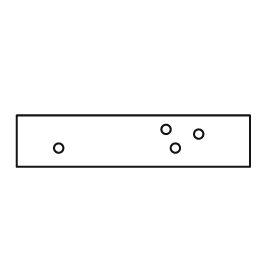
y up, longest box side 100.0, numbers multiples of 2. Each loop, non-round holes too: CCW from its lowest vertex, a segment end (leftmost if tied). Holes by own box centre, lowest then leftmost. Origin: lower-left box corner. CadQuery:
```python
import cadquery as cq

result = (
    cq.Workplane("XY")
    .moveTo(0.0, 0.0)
    .lineTo(100.0, 0.0)
    .lineTo(100.0, 22.0)
    .lineTo(0.0, 22.0)
    .close()
    .moveTo(18.0, 8.0)
    .circle(2.0)
    .moveTo(68.0, 8.0)
    .circle(2.0)
    .moveTo(78.0, 14.0)
    .circle(2.0)
    .moveTo(64.0, 16.0)
    .circle(2.0)
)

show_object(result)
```